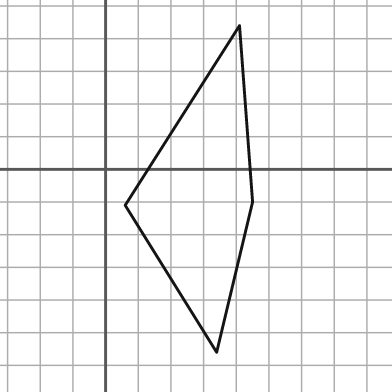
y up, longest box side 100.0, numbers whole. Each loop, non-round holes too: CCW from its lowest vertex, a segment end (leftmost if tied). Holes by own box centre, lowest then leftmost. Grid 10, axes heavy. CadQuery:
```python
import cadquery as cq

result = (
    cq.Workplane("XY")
    .moveTo(34.0, -56.0)
    .lineTo(45.0, -10.0)
    .lineTo(41.0, 44.0)
    .lineTo(6.0, -11.0)
    .close()
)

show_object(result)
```